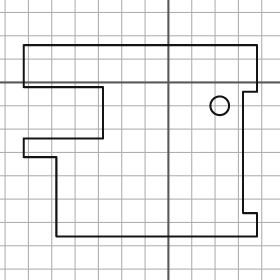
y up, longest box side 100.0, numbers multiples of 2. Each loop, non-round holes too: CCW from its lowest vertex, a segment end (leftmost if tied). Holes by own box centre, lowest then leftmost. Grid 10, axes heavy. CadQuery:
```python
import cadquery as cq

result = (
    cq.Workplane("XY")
    .moveTo(-48.0, -66.0)
    .lineTo(38.0, -66.0)
    .lineTo(38.0, -56.0)
    .lineTo(32.0, -56.0)
    .lineTo(32.0, -4.0)
    .lineTo(38.0, -4.0)
    .lineTo(38.0, 16.0)
    .lineTo(-62.0, 16.0)
    .lineTo(-62.0, -2.0)
    .lineTo(-28.0, -2.0)
    .lineTo(-28.0, -24.0)
    .lineTo(-62.0, -24.0)
    .lineTo(-62.0, -32.0)
    .lineTo(-48.0, -32.0)
    .close()
    .moveTo(22.0, -10.0)
    .circle(4.0)
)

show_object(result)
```